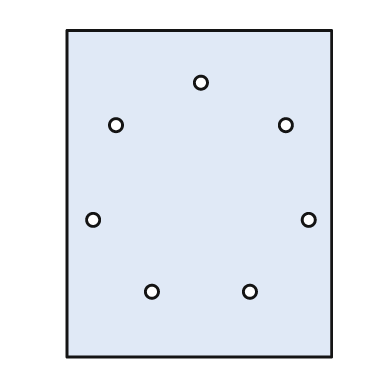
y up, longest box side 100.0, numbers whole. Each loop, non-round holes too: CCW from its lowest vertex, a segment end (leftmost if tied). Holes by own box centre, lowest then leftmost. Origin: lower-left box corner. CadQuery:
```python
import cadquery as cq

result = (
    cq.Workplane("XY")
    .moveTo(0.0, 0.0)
    .lineTo(81.0, 0.0)
    .lineTo(81.0, 100.0)
    .lineTo(0.0, 100.0)
    .close()
    .moveTo(26.0, 20.0)
    .circle(2.0)
    .moveTo(56.0, 20.0)
    .circle(2.0)
    .moveTo(8.0, 42.0)
    .circle(2.0)
    .moveTo(74.0, 42.0)
    .circle(2.0)
    .moveTo(15.0, 71.0)
    .circle(2.0)
    .moveTo(67.0, 71.0)
    .circle(2.0)
    .moveTo(41.0, 84.0)
    .circle(2.0)
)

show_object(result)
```